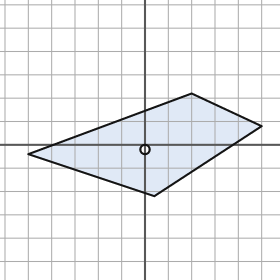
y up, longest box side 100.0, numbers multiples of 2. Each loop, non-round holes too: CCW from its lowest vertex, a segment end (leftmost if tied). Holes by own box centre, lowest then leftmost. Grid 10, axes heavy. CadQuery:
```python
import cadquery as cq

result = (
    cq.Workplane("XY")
    .moveTo(4.0, -22.0)
    .lineTo(50.0, 8.0)
    .lineTo(20.0, 22.0)
    .lineTo(-50.0, -4.0)
    .close()
    .moveTo(0.0, -2.0)
    .circle(2.0)
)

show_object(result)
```